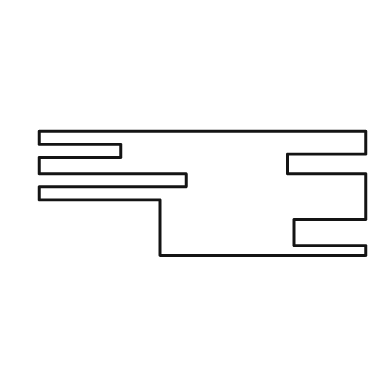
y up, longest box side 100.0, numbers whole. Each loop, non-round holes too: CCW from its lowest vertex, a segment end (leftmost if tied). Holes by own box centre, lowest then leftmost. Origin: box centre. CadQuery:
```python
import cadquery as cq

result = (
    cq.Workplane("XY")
    .moveTo(-13.0, -19.0)
    .lineTo(50.0, -19.0)
    .lineTo(50.0, -16.0)
    .lineTo(28.0, -16.0)
    .lineTo(28.0, -8.0)
    .lineTo(50.0, -8.0)
    .lineTo(50.0, 6.0)
    .lineTo(26.0, 6.0)
    .lineTo(26.0, 12.0)
    .lineTo(50.0, 12.0)
    .lineTo(50.0, 19.0)
    .lineTo(-50.0, 19.0)
    .lineTo(-50.0, 15.0)
    .lineTo(-25.0, 15.0)
    .lineTo(-25.0, 11.0)
    .lineTo(-50.0, 11.0)
    .lineTo(-50.0, 6.0)
    .lineTo(-5.0, 6.0)
    .lineTo(-5.0, 2.0)
    .lineTo(-50.0, 2.0)
    .lineTo(-50.0, -2.0)
    .lineTo(-13.0, -2.0)
    .close()
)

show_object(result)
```